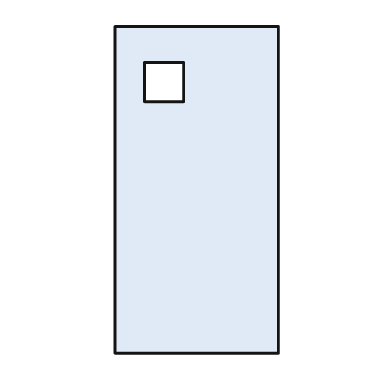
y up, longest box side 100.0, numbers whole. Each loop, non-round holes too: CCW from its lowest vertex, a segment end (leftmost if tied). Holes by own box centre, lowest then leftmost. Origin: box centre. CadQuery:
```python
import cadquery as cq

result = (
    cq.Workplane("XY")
    .moveTo(-25.0, -50.0)
    .lineTo(25.0, -50.0)
    .lineTo(25.0, 50.0)
    .lineTo(-25.0, 50.0)
    .close()
    .moveTo(-16.0, 27.0)
    .lineTo(-4.0, 27.0)
    .lineTo(-4.0, 39.0)
    .lineTo(-16.0, 39.0)
    .close()
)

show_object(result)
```